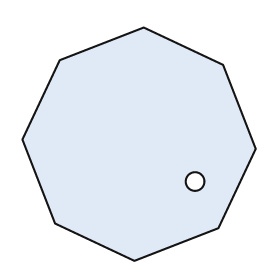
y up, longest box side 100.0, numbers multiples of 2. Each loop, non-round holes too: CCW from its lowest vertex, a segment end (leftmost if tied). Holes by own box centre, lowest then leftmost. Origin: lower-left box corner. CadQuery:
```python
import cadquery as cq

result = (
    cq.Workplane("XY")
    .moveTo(48.0, 0.0)
    .lineTo(84.0, 14.0)
    .lineTo(100.0, 48.0)
    .lineTo(86.0, 84.0)
    .lineTo(52.0, 100.0)
    .lineTo(16.0, 86.0)
    .lineTo(0.0, 52.0)
    .lineTo(14.0, 16.0)
    .close()
    .moveTo(74.0, 34.0)
    .circle(4.0)
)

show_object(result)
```